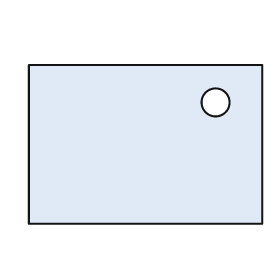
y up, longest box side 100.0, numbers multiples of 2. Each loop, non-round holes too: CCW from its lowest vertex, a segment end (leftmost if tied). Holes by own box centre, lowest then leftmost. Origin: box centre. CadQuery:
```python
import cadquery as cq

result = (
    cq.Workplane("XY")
    .moveTo(-50.0, -34.0)
    .lineTo(50.0, -34.0)
    .lineTo(50.0, 34.0)
    .lineTo(-50.0, 34.0)
    .close()
    .moveTo(30.0, 18.0)
    .circle(6.0)
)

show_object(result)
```